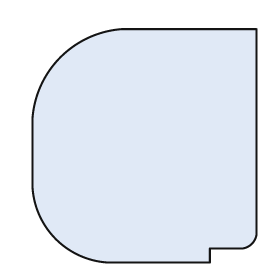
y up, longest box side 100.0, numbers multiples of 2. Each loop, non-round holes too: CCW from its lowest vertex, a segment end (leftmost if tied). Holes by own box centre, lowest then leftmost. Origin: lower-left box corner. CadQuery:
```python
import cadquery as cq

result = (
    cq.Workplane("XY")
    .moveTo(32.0, 0.0)
    .lineTo(76.0, 0.0)
    .lineTo(76.0, 6.0)
    .lineTo(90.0, 6.0)
    .threePointArc((94.0, 8.0), (96.0, 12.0))
    .lineTo(96.0, 100.0)
    .lineTo(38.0, 100.0)
    .threePointArc((12.0, 88.0), (0.0, 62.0))
    .lineTo(0.0, 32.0)
    .threePointArc((10.0, 10.0), (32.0, 0.0))
    .close()
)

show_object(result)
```